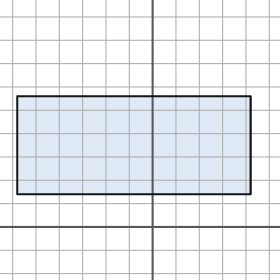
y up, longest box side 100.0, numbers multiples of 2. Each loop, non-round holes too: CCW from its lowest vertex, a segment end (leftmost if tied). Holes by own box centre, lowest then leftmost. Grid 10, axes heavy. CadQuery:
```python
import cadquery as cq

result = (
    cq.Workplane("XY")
    .moveTo(-58.0, 14.0)
    .lineTo(42.0, 14.0)
    .lineTo(42.0, 56.0)
    .lineTo(-58.0, 56.0)
    .close()
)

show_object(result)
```